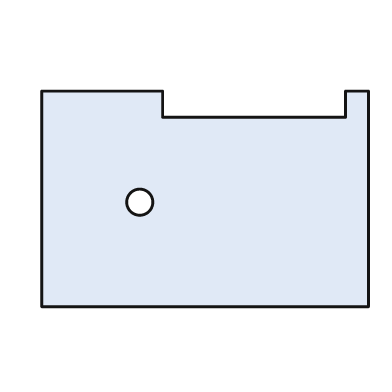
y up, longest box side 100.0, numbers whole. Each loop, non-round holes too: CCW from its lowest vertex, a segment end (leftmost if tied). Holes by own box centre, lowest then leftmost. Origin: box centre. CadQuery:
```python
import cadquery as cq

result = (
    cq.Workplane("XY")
    .moveTo(-50.0, -33.0)
    .lineTo(50.0, -33.0)
    .lineTo(50.0, 33.0)
    .lineTo(43.0, 33.0)
    .lineTo(43.0, 25.0)
    .lineTo(-13.0, 25.0)
    .lineTo(-13.0, 33.0)
    .lineTo(-50.0, 33.0)
    .close()
    .moveTo(-20.0, -1.0)
    .circle(4.0)
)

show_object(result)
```